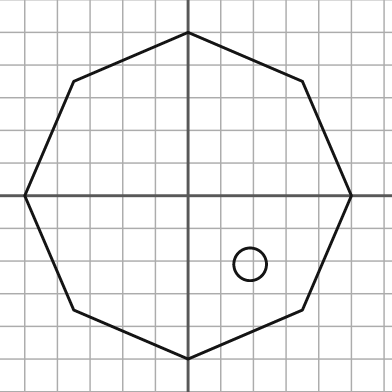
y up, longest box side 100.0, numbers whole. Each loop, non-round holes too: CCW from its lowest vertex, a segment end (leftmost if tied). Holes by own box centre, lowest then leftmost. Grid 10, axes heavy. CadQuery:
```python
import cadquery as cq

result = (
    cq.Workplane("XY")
    .moveTo(0.0, -50.0)
    .lineTo(35.0, -35.0)
    .lineTo(50.0, 0.0)
    .lineTo(35.0, 35.0)
    .lineTo(0.0, 50.0)
    .lineTo(-35.0, 35.0)
    .lineTo(-50.0, 0.0)
    .lineTo(-35.0, -35.0)
    .close()
    .moveTo(19.0, -21.0)
    .circle(5.0)
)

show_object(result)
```